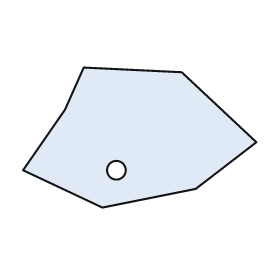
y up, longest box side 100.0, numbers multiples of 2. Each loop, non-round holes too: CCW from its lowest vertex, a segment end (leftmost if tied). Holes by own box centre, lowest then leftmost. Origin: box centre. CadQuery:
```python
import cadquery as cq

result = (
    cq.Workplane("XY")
    .moveTo(-16.0, -30.0)
    .lineTo(24.0, -22.0)
    .lineTo(50.0, -2.0)
    .lineTo(18.0, 28.0)
    .lineTo(-24.0, 30.0)
    .lineTo(-32.0, 12.0)
    .lineTo(-50.0, -14.0)
    .close()
    .moveTo(-10.0, -14.0)
    .circle(4.0)
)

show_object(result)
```